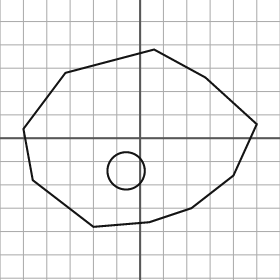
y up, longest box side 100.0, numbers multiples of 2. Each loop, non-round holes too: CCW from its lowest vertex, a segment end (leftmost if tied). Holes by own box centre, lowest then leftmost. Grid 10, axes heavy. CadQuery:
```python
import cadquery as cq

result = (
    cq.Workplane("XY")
    .moveTo(-20.0, -38.0)
    .lineTo(4.0, -36.0)
    .lineTo(22.0, -30.0)
    .lineTo(40.0, -16.0)
    .lineTo(50.0, 6.0)
    .lineTo(28.0, 26.0)
    .lineTo(6.0, 38.0)
    .lineTo(-32.0, 28.0)
    .lineTo(-50.0, 4.0)
    .lineTo(-46.0, -18.0)
    .close()
    .moveTo(-6.0, -14.0)
    .circle(8.0)
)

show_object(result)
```